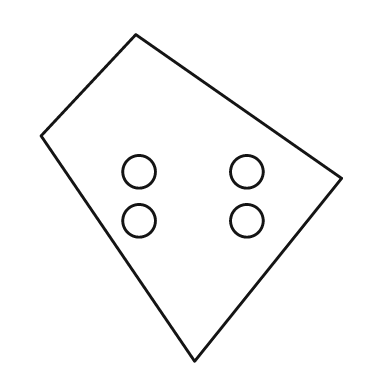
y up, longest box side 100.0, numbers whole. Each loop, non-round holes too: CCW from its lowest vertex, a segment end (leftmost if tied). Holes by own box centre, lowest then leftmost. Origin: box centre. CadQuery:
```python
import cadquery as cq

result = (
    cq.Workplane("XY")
    .moveTo(1.0, -50.0)
    .lineTo(46.0, 6.0)
    .lineTo(-17.0, 50.0)
    .lineTo(-46.0, 19.0)
    .close()
    .moveTo(-16.0, -7.0)
    .circle(5.0)
    .moveTo(17.0, -7.0)
    .circle(5.0)
    .moveTo(-16.0, 8.0)
    .circle(5.0)
    .moveTo(17.0, 8.0)
    .circle(5.0)
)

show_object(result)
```